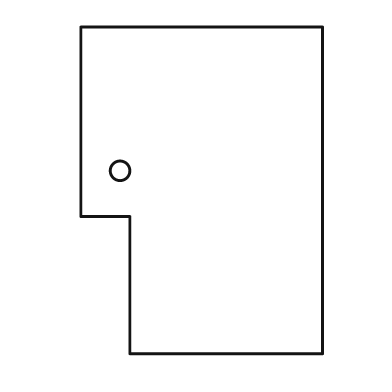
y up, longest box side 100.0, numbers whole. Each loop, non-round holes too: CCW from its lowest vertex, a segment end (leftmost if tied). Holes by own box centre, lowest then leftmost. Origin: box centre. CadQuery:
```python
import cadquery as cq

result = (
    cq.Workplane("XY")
    .moveTo(-22.0, -50.0)
    .lineTo(37.0, -50.0)
    .lineTo(37.0, 50.0)
    .lineTo(-37.0, 50.0)
    .lineTo(-37.0, -8.0)
    .lineTo(-22.0, -8.0)
    .close()
    .moveTo(-25.0, 6.0)
    .circle(3.0)
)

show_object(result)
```